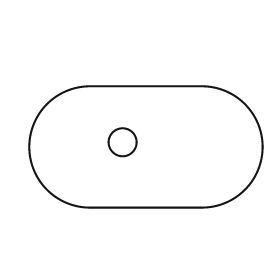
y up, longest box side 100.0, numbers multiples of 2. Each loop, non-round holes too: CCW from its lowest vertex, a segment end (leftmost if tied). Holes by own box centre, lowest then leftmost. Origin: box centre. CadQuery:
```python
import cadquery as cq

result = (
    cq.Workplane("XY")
    .moveTo(-24.0, -26.0)
    .lineTo(24.0, -26.0)
    .threePointArc((50.0, 0.0), (24.0, 26.0))
    .lineTo(-24.0, 26.0)
    .threePointArc((-50.0, 0.0), (-24.0, -26.0))
    .close()
    .moveTo(-10.0, 2.0)
    .circle(6.0)
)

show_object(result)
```